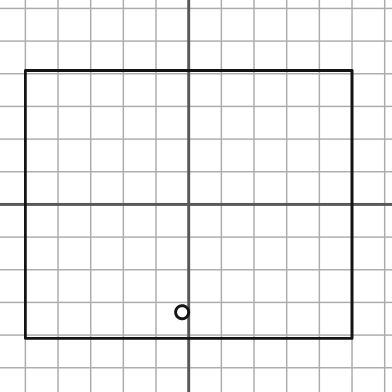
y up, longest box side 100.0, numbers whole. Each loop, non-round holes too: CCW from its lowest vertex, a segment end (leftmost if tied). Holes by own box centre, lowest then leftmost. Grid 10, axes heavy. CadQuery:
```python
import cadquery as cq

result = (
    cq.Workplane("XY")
    .moveTo(-50.0, -41.0)
    .lineTo(50.0, -41.0)
    .lineTo(50.0, 41.0)
    .lineTo(-50.0, 41.0)
    .close()
    .moveTo(-2.0, -33.0)
    .circle(2.0)
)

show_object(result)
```